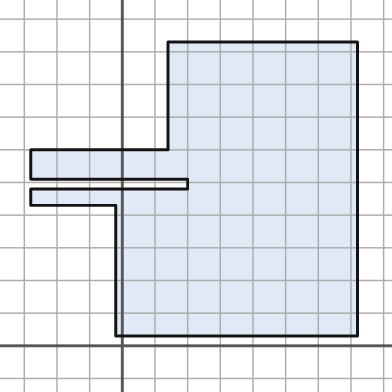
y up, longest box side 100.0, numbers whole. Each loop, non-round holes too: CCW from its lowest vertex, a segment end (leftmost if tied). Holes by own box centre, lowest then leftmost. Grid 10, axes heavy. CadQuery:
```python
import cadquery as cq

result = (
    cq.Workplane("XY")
    .moveTo(-2.0, 3.0)
    .lineTo(72.0, 3.0)
    .lineTo(72.0, 93.0)
    .lineTo(14.0, 93.0)
    .lineTo(14.0, 60.0)
    .lineTo(-28.0, 60.0)
    .lineTo(-28.0, 51.0)
    .lineTo(20.0, 51.0)
    .lineTo(20.0, 48.0)
    .lineTo(-28.0, 48.0)
    .lineTo(-28.0, 43.0)
    .lineTo(-2.0, 43.0)
    .close()
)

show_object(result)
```